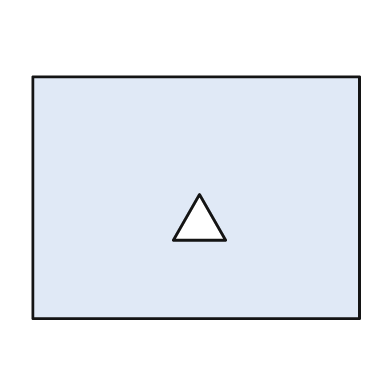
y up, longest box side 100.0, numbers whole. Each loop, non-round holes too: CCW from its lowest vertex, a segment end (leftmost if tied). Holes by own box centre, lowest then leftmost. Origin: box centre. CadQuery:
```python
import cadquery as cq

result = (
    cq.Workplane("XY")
    .moveTo(-50.0, -37.0)
    .lineTo(50.0, -37.0)
    .lineTo(50.0, 37.0)
    .lineTo(-50.0, 37.0)
    .close()
    .moveTo(-7.0, -13.0)
    .lineTo(9.0, -13.0)
    .lineTo(1.0, 1.0)
    .close()
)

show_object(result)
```